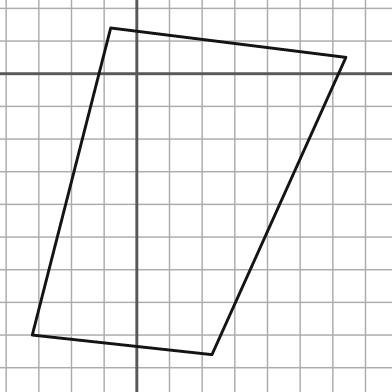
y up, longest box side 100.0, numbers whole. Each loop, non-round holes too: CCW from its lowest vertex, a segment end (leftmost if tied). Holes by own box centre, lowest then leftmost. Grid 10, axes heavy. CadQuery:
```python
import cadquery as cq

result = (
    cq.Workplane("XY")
    .moveTo(23.0, -86.0)
    .lineTo(64.0, 5.0)
    .lineTo(-8.0, 14.0)
    .lineTo(-32.0, -80.0)
    .close()
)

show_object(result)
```